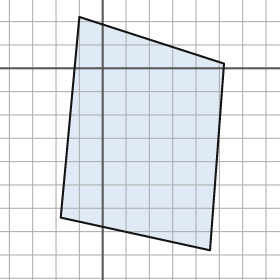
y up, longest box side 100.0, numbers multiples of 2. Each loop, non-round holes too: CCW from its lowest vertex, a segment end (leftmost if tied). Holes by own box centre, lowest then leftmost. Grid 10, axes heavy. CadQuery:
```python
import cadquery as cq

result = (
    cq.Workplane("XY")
    .moveTo(46.0, -78.0)
    .lineTo(52.0, 2.0)
    .lineTo(-10.0, 22.0)
    .lineTo(-18.0, -64.0)
    .close()
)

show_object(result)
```